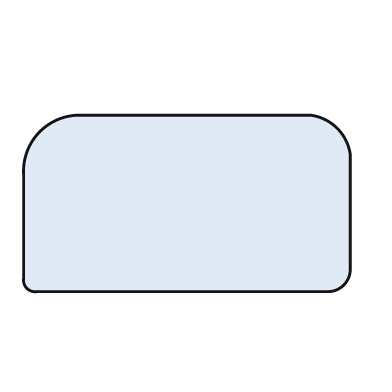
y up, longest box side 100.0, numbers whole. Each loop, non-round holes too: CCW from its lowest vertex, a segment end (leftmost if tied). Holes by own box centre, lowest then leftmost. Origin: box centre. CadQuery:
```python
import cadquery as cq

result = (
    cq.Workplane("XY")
    .moveTo(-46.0, -27.0)
    .lineTo(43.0, -27.0)
    .threePointArc((48.0, -25.0), (50.0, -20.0))
    .lineTo(50.0, 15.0)
    .threePointArc((46.0, 23.0), (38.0, 27.0))
    .lineTo(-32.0, 27.0)
    .threePointArc((-45.0, 22.0), (-50.0, 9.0))
    .lineTo(-50.0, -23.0)
    .threePointArc((-49.0, -26.0), (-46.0, -27.0))
    .close()
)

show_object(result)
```